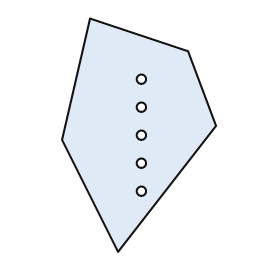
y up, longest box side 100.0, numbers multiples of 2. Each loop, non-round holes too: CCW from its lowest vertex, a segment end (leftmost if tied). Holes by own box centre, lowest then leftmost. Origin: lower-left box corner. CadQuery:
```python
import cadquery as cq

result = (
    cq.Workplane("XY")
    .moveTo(24.0, 0.0)
    .lineTo(66.0, 54.0)
    .lineTo(54.0, 86.0)
    .lineTo(12.0, 100.0)
    .lineTo(0.0, 48.0)
    .close()
    .moveTo(34.0, 26.0)
    .circle(2.0)
    .moveTo(34.0, 38.0)
    .circle(2.0)
    .moveTo(34.0, 50.0)
    .circle(2.0)
    .moveTo(34.0, 62.0)
    .circle(2.0)
    .moveTo(34.0, 74.0)
    .circle(2.0)
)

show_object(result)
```